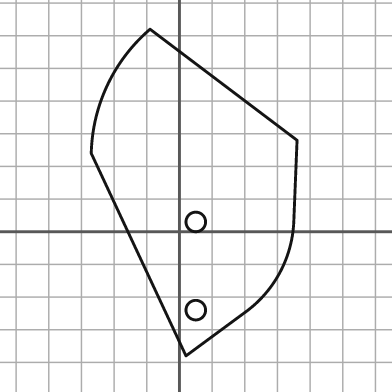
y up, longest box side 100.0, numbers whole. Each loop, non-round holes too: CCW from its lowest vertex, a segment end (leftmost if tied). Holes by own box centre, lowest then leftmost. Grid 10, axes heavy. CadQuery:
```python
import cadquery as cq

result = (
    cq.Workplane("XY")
    .moveTo(2.0, -38.0)
    .lineTo(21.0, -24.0)
    .threePointArc((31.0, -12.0), (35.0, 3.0))
    .lineTo(36.0, 28.0)
    .lineTo(-9.0, 62.0)
    .threePointArc((-22.0, 45.0), (-27.0, 24.0))
    .close()
    .moveTo(5.0, -24.0)
    .circle(3.0)
    .moveTo(5.0, 3.0)
    .circle(3.0)
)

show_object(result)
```